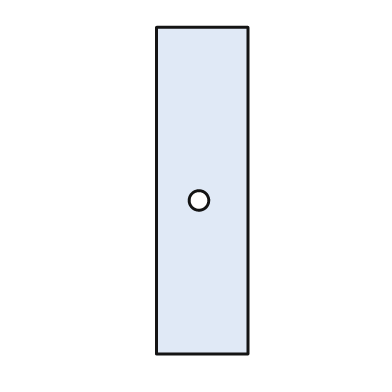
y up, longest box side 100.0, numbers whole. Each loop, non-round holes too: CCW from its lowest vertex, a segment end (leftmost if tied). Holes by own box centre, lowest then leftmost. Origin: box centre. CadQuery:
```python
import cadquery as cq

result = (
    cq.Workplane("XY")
    .moveTo(-14.0, -50.0)
    .lineTo(14.0, -50.0)
    .lineTo(14.0, 50.0)
    .lineTo(-14.0, 50.0)
    .close()
    .moveTo(-1.0, -3.0)
    .circle(3.0)
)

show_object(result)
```